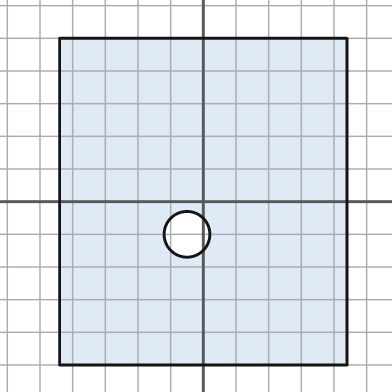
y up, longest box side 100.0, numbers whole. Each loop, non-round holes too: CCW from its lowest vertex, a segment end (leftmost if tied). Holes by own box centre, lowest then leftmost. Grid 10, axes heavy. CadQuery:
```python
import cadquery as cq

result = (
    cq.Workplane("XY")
    .moveTo(-44.0, -50.0)
    .lineTo(44.0, -50.0)
    .lineTo(44.0, 50.0)
    .lineTo(-44.0, 50.0)
    .close()
    .moveTo(-5.0, -10.0)
    .circle(7.0)
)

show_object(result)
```